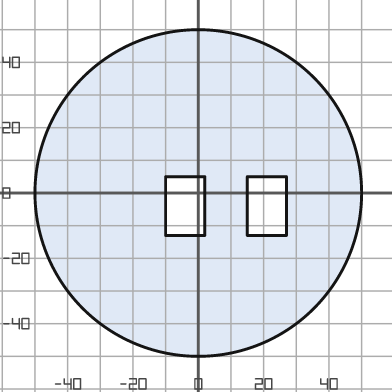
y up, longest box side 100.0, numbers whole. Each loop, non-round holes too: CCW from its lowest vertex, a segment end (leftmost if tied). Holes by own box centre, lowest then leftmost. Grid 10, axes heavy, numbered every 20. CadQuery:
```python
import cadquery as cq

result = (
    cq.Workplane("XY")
    .moveTo(0.0, 0.0)
    .circle(50.0)
    .moveTo(-10.0, -13.0)
    .lineTo(2.0, -13.0)
    .lineTo(2.0, 5.0)
    .lineTo(-10.0, 5.0)
    .close()
    .moveTo(15.0, -13.0)
    .lineTo(27.0, -13.0)
    .lineTo(27.0, 5.0)
    .lineTo(15.0, 5.0)
    .close()
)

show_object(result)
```